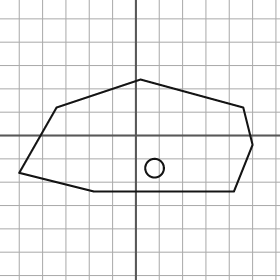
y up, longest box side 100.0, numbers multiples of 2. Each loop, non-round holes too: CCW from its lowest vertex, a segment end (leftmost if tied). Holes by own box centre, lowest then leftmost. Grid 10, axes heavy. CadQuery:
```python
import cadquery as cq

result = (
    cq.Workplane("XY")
    .moveTo(-18.0, -24.0)
    .lineTo(42.0, -24.0)
    .lineTo(50.0, -4.0)
    .lineTo(46.0, 12.0)
    .lineTo(2.0, 24.0)
    .lineTo(-34.0, 12.0)
    .lineTo(-50.0, -16.0)
    .close()
    .moveTo(8.0, -14.0)
    .circle(4.0)
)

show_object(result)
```